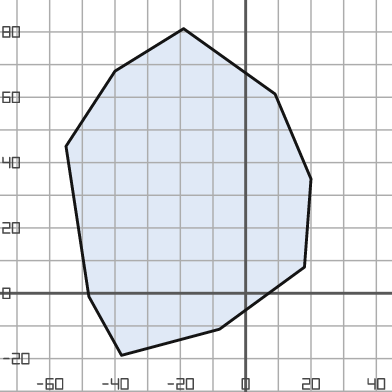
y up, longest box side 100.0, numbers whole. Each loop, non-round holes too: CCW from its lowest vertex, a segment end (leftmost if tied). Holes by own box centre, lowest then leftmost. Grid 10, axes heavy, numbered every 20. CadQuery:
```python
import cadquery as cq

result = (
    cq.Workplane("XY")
    .moveTo(-38.0, -19.0)
    .lineTo(-8.0, -11.0)
    .lineTo(18.0, 8.0)
    .lineTo(20.0, 35.0)
    .lineTo(9.0, 61.0)
    .lineTo(-19.0, 81.0)
    .lineTo(-40.0, 68.0)
    .lineTo(-55.0, 45.0)
    .lineTo(-48.0, -1.0)
    .close()
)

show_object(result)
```